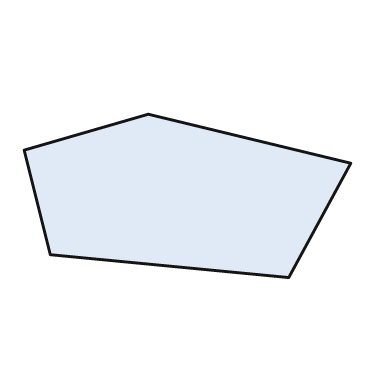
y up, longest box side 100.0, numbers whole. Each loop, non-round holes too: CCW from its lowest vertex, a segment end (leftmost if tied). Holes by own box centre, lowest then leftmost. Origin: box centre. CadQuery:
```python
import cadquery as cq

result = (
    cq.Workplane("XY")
    .moveTo(31.0, -25.0)
    .lineTo(50.0, 10.0)
    .lineTo(-12.0, 25.0)
    .lineTo(-50.0, 14.0)
    .lineTo(-42.0, -18.0)
    .close()
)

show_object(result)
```